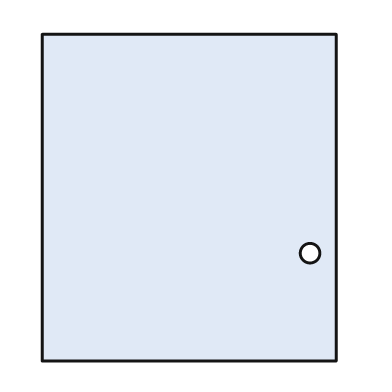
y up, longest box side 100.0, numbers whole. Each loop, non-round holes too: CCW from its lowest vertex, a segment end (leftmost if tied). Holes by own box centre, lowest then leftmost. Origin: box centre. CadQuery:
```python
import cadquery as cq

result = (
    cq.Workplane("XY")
    .moveTo(-45.0, -50.0)
    .lineTo(45.0, -50.0)
    .lineTo(45.0, 50.0)
    .lineTo(-45.0, 50.0)
    .close()
    .moveTo(37.0, -17.0)
    .circle(3.0)
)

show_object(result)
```